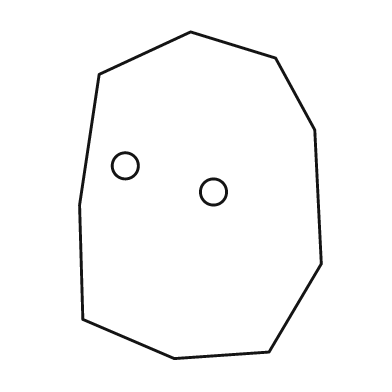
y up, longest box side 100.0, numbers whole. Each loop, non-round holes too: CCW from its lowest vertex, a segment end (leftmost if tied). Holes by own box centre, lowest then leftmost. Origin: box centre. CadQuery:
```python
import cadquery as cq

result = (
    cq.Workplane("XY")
    .moveTo(-8.0, -50.0)
    .lineTo(21.0, -48.0)
    .lineTo(37.0, -21.0)
    .lineTo(35.0, 20.0)
    .lineTo(23.0, 42.0)
    .lineTo(-3.0, 50.0)
    .lineTo(-31.0, 37.0)
    .lineTo(-37.0, -3.0)
    .lineTo(-36.0, -38.0)
    .close()
    .moveTo(4.0, 1.0)
    .circle(4.0)
    .moveTo(-23.0, 9.0)
    .circle(4.0)
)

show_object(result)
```